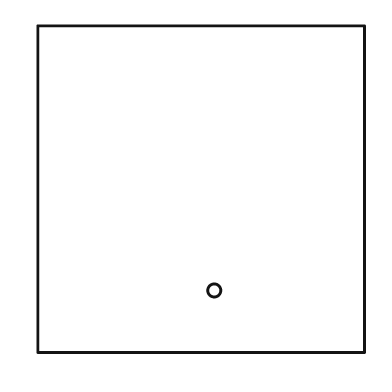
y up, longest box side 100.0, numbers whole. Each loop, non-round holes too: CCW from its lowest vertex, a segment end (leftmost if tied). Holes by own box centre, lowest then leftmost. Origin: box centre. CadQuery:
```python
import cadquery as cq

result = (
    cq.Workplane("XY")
    .moveTo(-50.0, -50.0)
    .lineTo(50.0, -50.0)
    .lineTo(50.0, 50.0)
    .lineTo(-50.0, 50.0)
    .close()
    .moveTo(4.0, -31.0)
    .circle(2.0)
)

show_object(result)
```